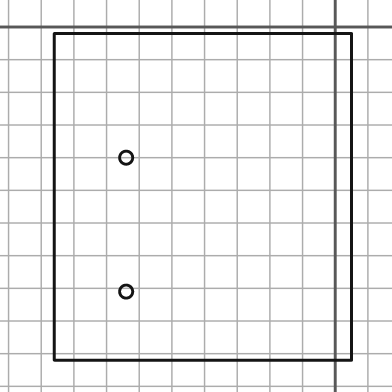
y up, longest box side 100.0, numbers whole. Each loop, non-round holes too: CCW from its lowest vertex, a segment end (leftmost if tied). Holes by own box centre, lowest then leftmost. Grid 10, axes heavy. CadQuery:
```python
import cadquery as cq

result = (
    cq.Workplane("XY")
    .moveTo(-86.0, -102.0)
    .lineTo(5.0, -102.0)
    .lineTo(5.0, -2.0)
    .lineTo(-86.0, -2.0)
    .close()
    .moveTo(-64.0, -81.0)
    .circle(2.0)
    .moveTo(-64.0, -40.0)
    .circle(2.0)
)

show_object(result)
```